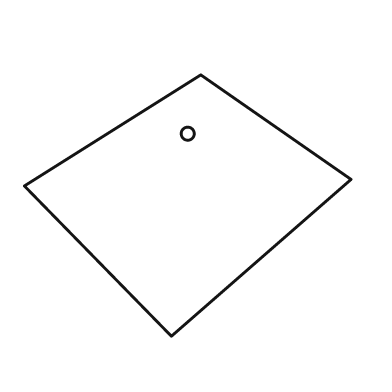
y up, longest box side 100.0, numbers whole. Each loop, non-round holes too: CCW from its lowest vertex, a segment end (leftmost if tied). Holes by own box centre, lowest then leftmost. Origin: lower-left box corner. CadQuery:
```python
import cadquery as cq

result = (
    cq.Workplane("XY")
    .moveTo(45.0, 0.0)
    .lineTo(100.0, 48.0)
    .lineTo(54.0, 80.0)
    .lineTo(0.0, 46.0)
    .close()
    .moveTo(50.0, 62.0)
    .circle(2.0)
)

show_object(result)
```